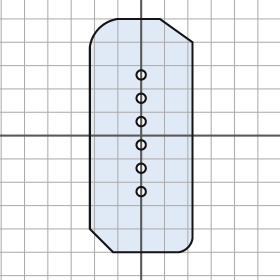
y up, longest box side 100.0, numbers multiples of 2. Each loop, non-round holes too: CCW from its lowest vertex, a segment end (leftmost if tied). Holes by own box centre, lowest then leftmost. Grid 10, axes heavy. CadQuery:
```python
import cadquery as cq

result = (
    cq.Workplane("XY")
    .moveTo(-12.0, -50.0)
    .lineTo(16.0, -50.0)
    .threePointArc((20.0, -48.0), (22.0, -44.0))
    .lineTo(22.0, 40.0)
    .lineTo(8.0, 50.0)
    .lineTo(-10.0, 50.0)
    .threePointArc((-18.0, 46.0), (-22.0, 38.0))
    .lineTo(-22.0, -40.0)
    .close()
    .moveTo(0.0, -24.0)
    .circle(2.0)
    .moveTo(0.0, -14.0)
    .circle(2.0)
    .moveTo(0.0, -4.0)
    .circle(2.0)
    .moveTo(0.0, 6.0)
    .circle(2.0)
    .moveTo(0.0, 16.0)
    .circle(2.0)
    .moveTo(0.0, 26.0)
    .circle(2.0)
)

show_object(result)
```